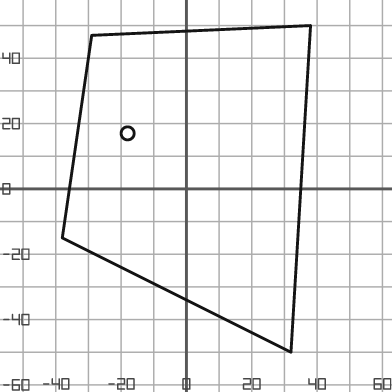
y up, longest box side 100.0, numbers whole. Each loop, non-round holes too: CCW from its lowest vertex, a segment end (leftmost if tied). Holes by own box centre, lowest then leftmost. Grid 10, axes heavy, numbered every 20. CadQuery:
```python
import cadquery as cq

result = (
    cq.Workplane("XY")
    .moveTo(32.0, -50.0)
    .lineTo(38.0, 50.0)
    .lineTo(-29.0, 47.0)
    .lineTo(-38.0, -15.0)
    .close()
    .moveTo(-18.0, 17.0)
    .circle(2.0)
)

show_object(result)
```